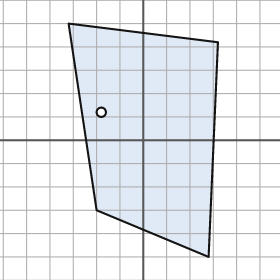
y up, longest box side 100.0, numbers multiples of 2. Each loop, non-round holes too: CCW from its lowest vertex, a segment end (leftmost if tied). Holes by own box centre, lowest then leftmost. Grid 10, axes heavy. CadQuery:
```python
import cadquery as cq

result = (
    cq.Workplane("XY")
    .moveTo(28.0, -50.0)
    .lineTo(32.0, 42.0)
    .lineTo(-32.0, 50.0)
    .lineTo(-20.0, -30.0)
    .close()
    .moveTo(-18.0, 12.0)
    .circle(2.0)
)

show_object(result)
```